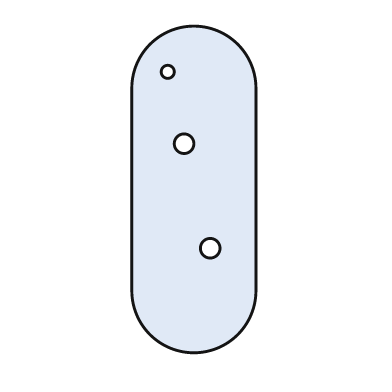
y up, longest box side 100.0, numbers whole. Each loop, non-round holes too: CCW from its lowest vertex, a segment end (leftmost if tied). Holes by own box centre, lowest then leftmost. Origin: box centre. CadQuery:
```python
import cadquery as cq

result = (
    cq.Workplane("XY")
    .moveTo(-19.0, -31.0)
    .threePointArc((0.0, -50.0), (19.0, -31.0))
    .lineTo(19.0, 31.0)
    .threePointArc((0.0, 50.0), (-19.0, 31.0))
    .close()
    .moveTo(5.0, -18.0)
    .circle(3.0)
    .moveTo(-3.0, 14.0)
    .circle(3.0)
    .moveTo(-8.0, 36.0)
    .circle(2.0)
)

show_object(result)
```